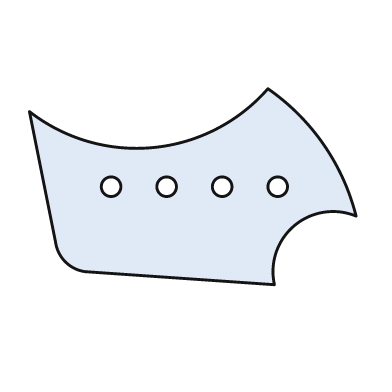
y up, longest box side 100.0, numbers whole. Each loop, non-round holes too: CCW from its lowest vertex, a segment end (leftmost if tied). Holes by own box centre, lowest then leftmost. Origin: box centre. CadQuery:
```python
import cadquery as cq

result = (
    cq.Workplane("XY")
    .moveTo(25.0, -30.0)
    .threePointArc((31.0, -12.0), (50.0, -9.0))
    .threePointArc((40.0, 13.0), (23.0, 30.0))
    .threePointArc((-12.0, 12.0), (-50.0, 23.0))
    .lineTo(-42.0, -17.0)
    .threePointArc((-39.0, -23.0), (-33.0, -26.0))
    .close()
    .moveTo(-25.0, 0.0)
    .circle(3.0)
    .moveTo(-8.0, 0.0)
    .circle(3.0)
    .moveTo(9.0, 0.0)
    .circle(3.0)
    .moveTo(26.0, 0.0)
    .circle(3.0)
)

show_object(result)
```